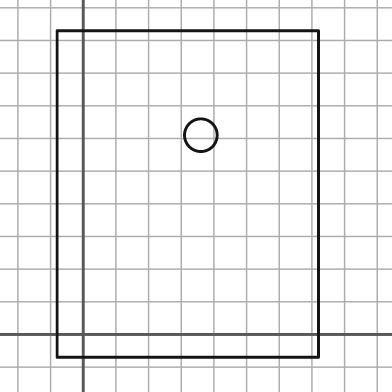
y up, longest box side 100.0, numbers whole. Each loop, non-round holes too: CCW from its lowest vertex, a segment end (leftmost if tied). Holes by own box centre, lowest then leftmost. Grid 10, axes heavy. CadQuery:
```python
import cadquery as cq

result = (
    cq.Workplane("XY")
    .moveTo(-8.0, -7.0)
    .lineTo(72.0, -7.0)
    .lineTo(72.0, 93.0)
    .lineTo(-8.0, 93.0)
    .close()
    .moveTo(36.0, 61.0)
    .circle(5.0)
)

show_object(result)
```